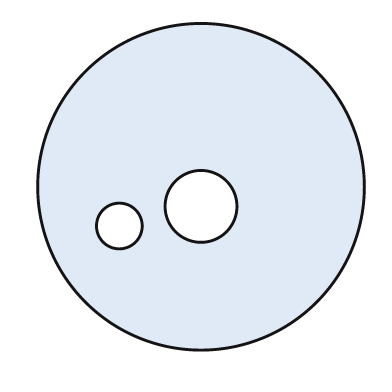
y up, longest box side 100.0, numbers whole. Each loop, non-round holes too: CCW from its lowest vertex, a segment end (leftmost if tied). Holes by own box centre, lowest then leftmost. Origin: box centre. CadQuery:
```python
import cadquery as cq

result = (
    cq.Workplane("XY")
    .moveTo(0.0, 0.0)
    .circle(50.0)
    .moveTo(-25.0, -12.0)
    .circle(7.0)
    .moveTo(0.0, -6.0)
    .circle(11.0)
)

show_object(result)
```